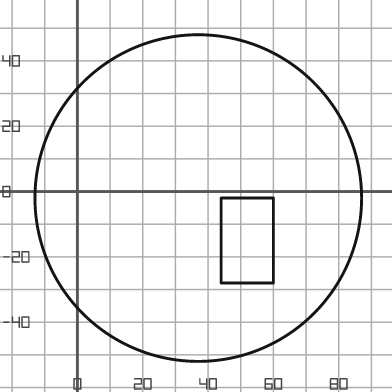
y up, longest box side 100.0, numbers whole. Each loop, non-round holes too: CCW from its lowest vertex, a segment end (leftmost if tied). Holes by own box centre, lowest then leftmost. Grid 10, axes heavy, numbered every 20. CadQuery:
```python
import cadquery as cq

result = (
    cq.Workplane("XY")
    .moveTo(37.0, -2.0)
    .circle(50.0)
    .moveTo(44.0, -28.0)
    .lineTo(60.0, -28.0)
    .lineTo(60.0, -2.0)
    .lineTo(44.0, -2.0)
    .close()
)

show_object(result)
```